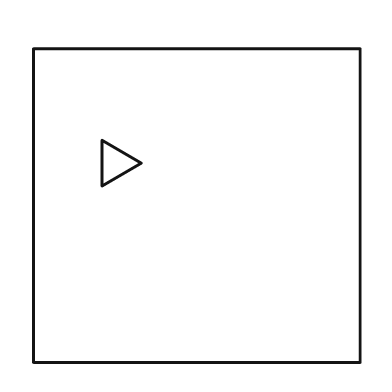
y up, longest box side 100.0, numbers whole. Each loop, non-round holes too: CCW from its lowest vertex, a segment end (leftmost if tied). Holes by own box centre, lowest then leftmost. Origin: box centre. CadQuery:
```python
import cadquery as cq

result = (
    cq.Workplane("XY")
    .moveTo(-50.0, -48.0)
    .lineTo(50.0, -48.0)
    .lineTo(50.0, 48.0)
    .lineTo(-50.0, 48.0)
    .close()
    .moveTo(-29.0, 6.0)
    .lineTo(-17.0, 13.0)
    .lineTo(-29.0, 20.0)
    .close()
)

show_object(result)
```